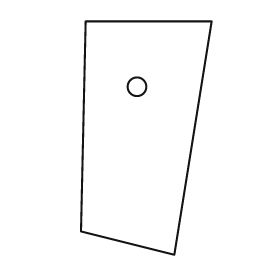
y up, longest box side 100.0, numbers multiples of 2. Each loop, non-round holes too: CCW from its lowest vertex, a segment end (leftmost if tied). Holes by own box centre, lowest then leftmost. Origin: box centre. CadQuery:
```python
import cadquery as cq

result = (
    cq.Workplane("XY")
    .moveTo(12.0, -50.0)
    .lineTo(28.0, 50.0)
    .lineTo(-26.0, 50.0)
    .lineTo(-28.0, -40.0)
    .close()
    .moveTo(-4.0, 22.0)
    .circle(4.0)
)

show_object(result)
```